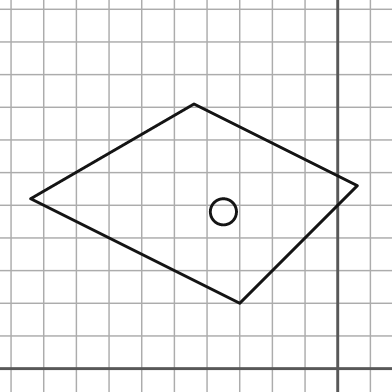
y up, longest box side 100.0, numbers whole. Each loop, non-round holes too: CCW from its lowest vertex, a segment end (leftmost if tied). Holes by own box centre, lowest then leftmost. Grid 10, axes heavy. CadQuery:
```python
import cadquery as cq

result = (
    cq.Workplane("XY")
    .moveTo(-30.0, 20.0)
    .lineTo(6.0, 56.0)
    .lineTo(-44.0, 81.0)
    .lineTo(-94.0, 52.0)
    .close()
    .moveTo(-35.0, 48.0)
    .circle(4.0)
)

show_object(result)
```